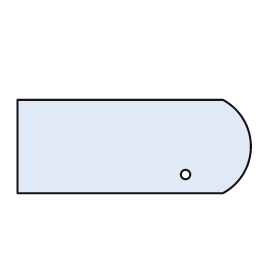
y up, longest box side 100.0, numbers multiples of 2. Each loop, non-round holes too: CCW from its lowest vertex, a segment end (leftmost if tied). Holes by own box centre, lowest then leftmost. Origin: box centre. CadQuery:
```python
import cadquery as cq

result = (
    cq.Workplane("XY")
    .moveTo(-50.0, -20.0)
    .lineTo(38.0, -20.0)
    .threePointArc((50.0, 0.0), (38.0, 20.0))
    .lineTo(-50.0, 20.0)
    .close()
    .moveTo(22.0, -12.0)
    .circle(2.0)
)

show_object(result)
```